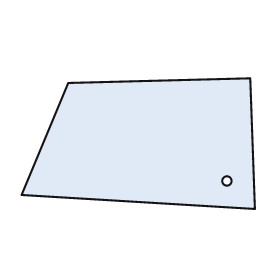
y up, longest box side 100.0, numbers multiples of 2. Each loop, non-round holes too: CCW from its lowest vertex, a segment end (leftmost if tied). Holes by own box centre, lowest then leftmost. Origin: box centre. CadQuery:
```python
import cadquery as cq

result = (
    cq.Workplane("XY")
    .moveTo(50.0, -28.0)
    .lineTo(48.0, 28.0)
    .lineTo(-30.0, 26.0)
    .lineTo(-50.0, -22.0)
    .close()
    .moveTo(38.0, -16.0)
    .circle(2.0)
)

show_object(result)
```